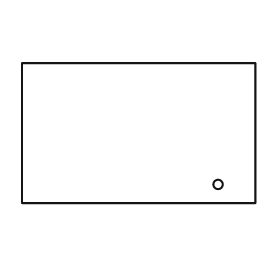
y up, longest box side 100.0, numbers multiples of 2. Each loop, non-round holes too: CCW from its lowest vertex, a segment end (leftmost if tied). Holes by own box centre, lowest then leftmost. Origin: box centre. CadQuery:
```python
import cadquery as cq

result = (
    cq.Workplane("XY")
    .moveTo(-50.0, -30.0)
    .lineTo(50.0, -30.0)
    .lineTo(50.0, 30.0)
    .lineTo(-50.0, 30.0)
    .close()
    .moveTo(34.0, -22.0)
    .circle(2.0)
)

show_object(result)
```